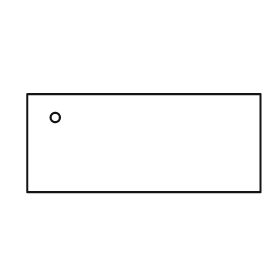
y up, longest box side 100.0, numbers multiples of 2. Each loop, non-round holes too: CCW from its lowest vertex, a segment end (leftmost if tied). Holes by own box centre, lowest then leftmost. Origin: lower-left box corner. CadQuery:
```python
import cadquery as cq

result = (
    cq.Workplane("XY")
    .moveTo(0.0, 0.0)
    .lineTo(100.0, 0.0)
    .lineTo(100.0, 42.0)
    .lineTo(0.0, 42.0)
    .close()
    .moveTo(12.0, 32.0)
    .circle(2.0)
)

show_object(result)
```